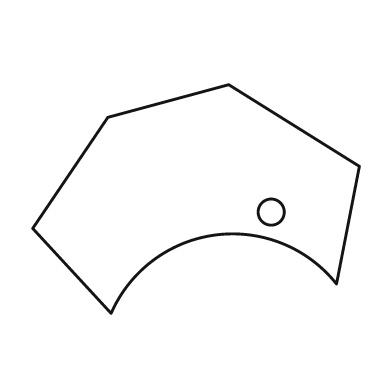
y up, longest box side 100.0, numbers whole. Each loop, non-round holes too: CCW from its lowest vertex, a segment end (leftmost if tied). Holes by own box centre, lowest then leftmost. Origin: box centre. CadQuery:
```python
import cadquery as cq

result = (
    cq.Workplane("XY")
    .moveTo(-26.0, -35.0)
    .threePointArc((6.0, -11.0), (43.0, -26.0))
    .lineTo(50.0, 10.0)
    .lineTo(10.0, 35.0)
    .lineTo(-27.0, 25.0)
    .lineTo(-50.0, -9.0)
    .close()
    .moveTo(23.0, -4.0)
    .circle(4.0)
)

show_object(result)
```